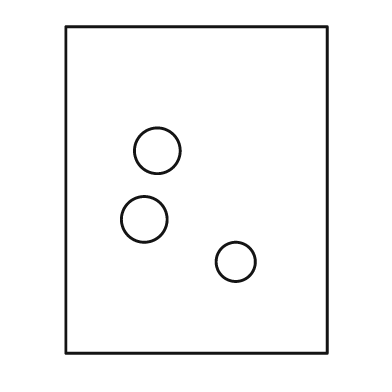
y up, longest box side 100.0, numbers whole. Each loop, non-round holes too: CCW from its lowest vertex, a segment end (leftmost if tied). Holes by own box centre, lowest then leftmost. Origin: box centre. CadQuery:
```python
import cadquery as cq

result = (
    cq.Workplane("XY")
    .moveTo(-40.0, -50.0)
    .lineTo(40.0, -50.0)
    .lineTo(40.0, 50.0)
    .lineTo(-40.0, 50.0)
    .close()
    .moveTo(12.0, -22.0)
    .circle(6.0)
    .moveTo(-16.0, -9.0)
    .circle(7.0)
    .moveTo(-12.0, 12.0)
    .circle(7.0)
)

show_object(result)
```